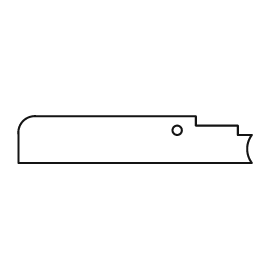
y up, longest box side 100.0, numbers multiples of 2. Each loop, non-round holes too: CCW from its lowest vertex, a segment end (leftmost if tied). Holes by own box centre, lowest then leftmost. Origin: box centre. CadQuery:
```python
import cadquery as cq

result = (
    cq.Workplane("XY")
    .moveTo(-50.0, -10.0)
    .lineTo(50.0, -10.0)
    .threePointArc((48.0, -4.0), (50.0, 2.0))
    .lineTo(44.0, 2.0)
    .lineTo(44.0, 6.0)
    .lineTo(26.0, 6.0)
    .lineTo(26.0, 10.0)
    .lineTo(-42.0, 10.0)
    .threePointArc((-48.0, 8.0), (-50.0, 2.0))
    .close()
    .moveTo(18.0, 4.0)
    .circle(2.0)
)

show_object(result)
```